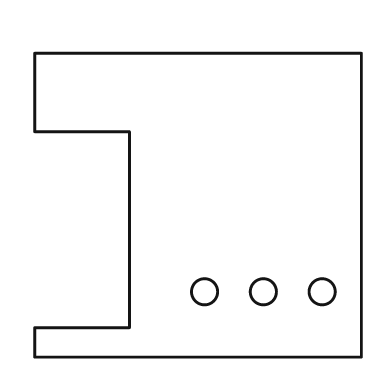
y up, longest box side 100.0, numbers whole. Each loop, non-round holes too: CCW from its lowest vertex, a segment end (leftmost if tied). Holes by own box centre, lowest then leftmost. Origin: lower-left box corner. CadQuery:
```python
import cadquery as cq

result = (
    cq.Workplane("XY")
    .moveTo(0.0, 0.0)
    .lineTo(100.0, 0.0)
    .lineTo(100.0, 93.0)
    .lineTo(0.0, 93.0)
    .lineTo(0.0, 69.0)
    .lineTo(29.0, 69.0)
    .lineTo(29.0, 9.0)
    .lineTo(0.0, 9.0)
    .close()
    .moveTo(52.0, 20.0)
    .circle(4.0)
    .moveTo(70.0, 20.0)
    .circle(4.0)
    .moveTo(88.0, 20.0)
    .circle(4.0)
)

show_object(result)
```